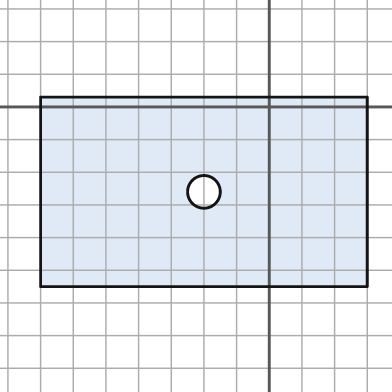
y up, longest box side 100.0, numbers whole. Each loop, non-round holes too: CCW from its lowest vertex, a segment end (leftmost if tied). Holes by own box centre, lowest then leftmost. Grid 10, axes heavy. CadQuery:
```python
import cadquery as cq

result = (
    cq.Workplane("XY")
    .moveTo(-70.0, -55.0)
    .lineTo(30.0, -55.0)
    .lineTo(30.0, 3.0)
    .lineTo(-70.0, 3.0)
    .close()
    .moveTo(-20.0, -26.0)
    .circle(5.0)
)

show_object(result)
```